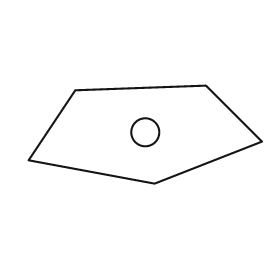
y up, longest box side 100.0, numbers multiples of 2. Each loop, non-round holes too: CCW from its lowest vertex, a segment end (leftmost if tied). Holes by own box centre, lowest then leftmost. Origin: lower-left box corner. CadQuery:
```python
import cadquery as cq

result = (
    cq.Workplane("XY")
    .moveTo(54.0, 0.0)
    .lineTo(100.0, 18.0)
    .lineTo(76.0, 42.0)
    .lineTo(20.0, 40.0)
    .lineTo(0.0, 10.0)
    .close()
    .moveTo(50.0, 22.0)
    .circle(6.0)
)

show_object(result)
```